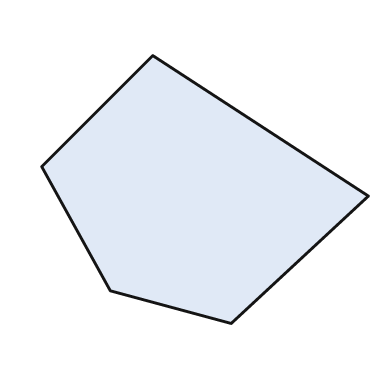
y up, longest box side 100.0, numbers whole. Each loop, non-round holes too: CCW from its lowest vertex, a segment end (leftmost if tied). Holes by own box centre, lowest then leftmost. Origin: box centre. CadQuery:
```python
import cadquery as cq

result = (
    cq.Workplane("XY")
    .moveTo(8.0, -41.0)
    .lineTo(50.0, -2.0)
    .lineTo(-16.0, 41.0)
    .lineTo(-50.0, 7.0)
    .lineTo(-29.0, -31.0)
    .close()
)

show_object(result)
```